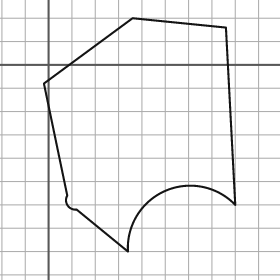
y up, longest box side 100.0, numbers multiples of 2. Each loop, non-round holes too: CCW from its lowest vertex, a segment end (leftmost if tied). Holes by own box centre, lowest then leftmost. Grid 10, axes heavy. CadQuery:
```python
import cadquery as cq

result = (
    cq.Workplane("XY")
    .moveTo(34.0, -80.0)
    .threePointArc((50.0, -54.0), (80.0, -60.0))
    .lineTo(76.0, 16.0)
    .lineTo(36.0, 20.0)
    .lineTo(-2.0, -8.0)
    .lineTo(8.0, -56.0)
    .threePointArc((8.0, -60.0), (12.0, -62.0))
    .close()
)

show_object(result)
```